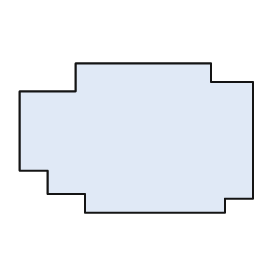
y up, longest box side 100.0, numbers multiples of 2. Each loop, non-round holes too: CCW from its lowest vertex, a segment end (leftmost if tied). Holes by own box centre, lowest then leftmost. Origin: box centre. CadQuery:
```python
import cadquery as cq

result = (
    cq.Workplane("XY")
    .moveTo(-22.0, -32.0)
    .lineTo(38.0, -32.0)
    .lineTo(38.0, -26.0)
    .lineTo(50.0, -26.0)
    .lineTo(50.0, 24.0)
    .lineTo(32.0, 24.0)
    .lineTo(32.0, 32.0)
    .lineTo(-26.0, 32.0)
    .lineTo(-26.0, 20.0)
    .lineTo(-50.0, 20.0)
    .lineTo(-50.0, -14.0)
    .lineTo(-38.0, -14.0)
    .lineTo(-38.0, -24.0)
    .lineTo(-22.0, -24.0)
    .close()
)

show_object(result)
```